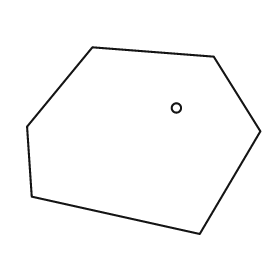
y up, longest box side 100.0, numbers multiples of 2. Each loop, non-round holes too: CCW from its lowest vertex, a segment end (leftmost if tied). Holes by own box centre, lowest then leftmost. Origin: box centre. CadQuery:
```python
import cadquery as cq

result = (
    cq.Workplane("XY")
    .moveTo(24.0, -40.0)
    .lineTo(50.0, 4.0)
    .lineTo(30.0, 36.0)
    .lineTo(-22.0, 40.0)
    .lineTo(-50.0, 6.0)
    .lineTo(-48.0, -24.0)
    .close()
    .moveTo(14.0, 14.0)
    .circle(2.0)
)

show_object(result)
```